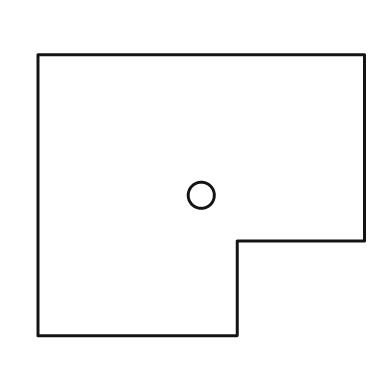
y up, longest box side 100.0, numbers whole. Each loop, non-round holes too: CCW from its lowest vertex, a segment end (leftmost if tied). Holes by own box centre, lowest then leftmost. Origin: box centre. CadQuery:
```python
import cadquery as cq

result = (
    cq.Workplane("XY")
    .moveTo(-50.0, -43.0)
    .lineTo(11.0, -43.0)
    .lineTo(11.0, -14.0)
    .lineTo(50.0, -14.0)
    .lineTo(50.0, 43.0)
    .lineTo(-50.0, 43.0)
    .close()
    .moveTo(0.0, 0.0)
    .circle(4.0)
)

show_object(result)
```